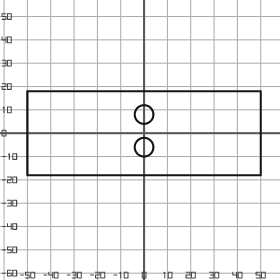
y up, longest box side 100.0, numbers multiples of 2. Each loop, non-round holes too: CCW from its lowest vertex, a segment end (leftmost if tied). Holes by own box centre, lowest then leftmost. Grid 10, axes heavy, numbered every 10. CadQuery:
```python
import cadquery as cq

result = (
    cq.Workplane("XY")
    .moveTo(-50.0, -18.0)
    .lineTo(50.0, -18.0)
    .lineTo(50.0, 18.0)
    .lineTo(-50.0, 18.0)
    .close()
    .moveTo(0.0, -6.0)
    .circle(4.0)
    .moveTo(0.0, 8.0)
    .circle(4.0)
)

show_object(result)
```